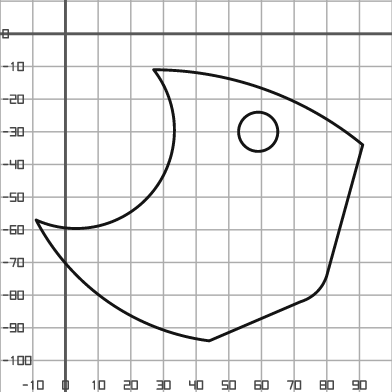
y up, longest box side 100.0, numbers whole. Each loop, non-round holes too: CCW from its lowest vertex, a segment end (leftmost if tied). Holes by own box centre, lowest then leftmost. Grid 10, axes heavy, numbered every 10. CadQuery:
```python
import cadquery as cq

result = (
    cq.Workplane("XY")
    .moveTo(44.0, -94.0)
    .lineTo(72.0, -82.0)
    .threePointArc((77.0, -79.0), (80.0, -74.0))
    .lineTo(91.0, -34.0)
    .threePointArc((61.0, -17.0), (27.0, -11.0))
    .threePointArc((27.0, -48.0), (-9.0, -57.0))
    .threePointArc((13.0, -82.0), (44.0, -94.0))
    .close()
    .moveTo(59.0, -30.0)
    .circle(6.0)
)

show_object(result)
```